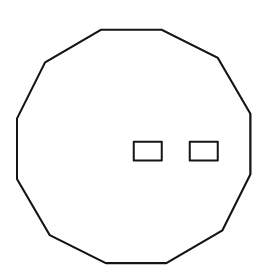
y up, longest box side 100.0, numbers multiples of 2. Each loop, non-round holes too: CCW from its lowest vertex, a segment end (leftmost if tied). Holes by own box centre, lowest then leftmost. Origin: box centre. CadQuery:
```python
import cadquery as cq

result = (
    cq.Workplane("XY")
    .moveTo(-12.0, -50.0)
    .lineTo(14.0, -50.0)
    .lineTo(38.0, -36.0)
    .lineTo(50.0, -12.0)
    .lineTo(50.0, 14.0)
    .lineTo(36.0, 38.0)
    .lineTo(12.0, 50.0)
    .lineTo(-14.0, 50.0)
    .lineTo(-38.0, 36.0)
    .lineTo(-50.0, 12.0)
    .lineTo(-50.0, -14.0)
    .lineTo(-36.0, -38.0)
    .close()
    .moveTo(0.0, -6.0)
    .lineTo(12.0, -6.0)
    .lineTo(12.0, 2.0)
    .lineTo(0.0, 2.0)
    .close()
    .moveTo(24.0, -6.0)
    .lineTo(36.0, -6.0)
    .lineTo(36.0, 2.0)
    .lineTo(24.0, 2.0)
    .close()
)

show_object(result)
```